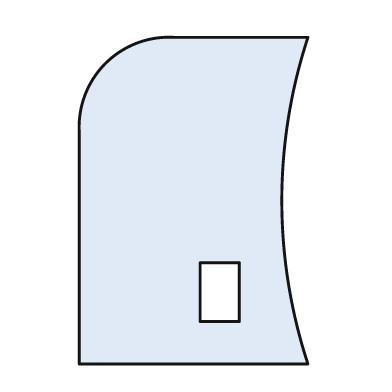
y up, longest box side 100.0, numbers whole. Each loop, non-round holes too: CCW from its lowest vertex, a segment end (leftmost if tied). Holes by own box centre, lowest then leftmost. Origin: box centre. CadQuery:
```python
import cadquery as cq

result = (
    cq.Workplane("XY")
    .moveTo(-35.0, -50.0)
    .lineTo(35.0, -50.0)
    .threePointArc((27.0, 0.0), (35.0, 50.0))
    .lineTo(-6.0, 50.0)
    .threePointArc((-27.0, 42.0), (-35.0, 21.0))
    .close()
    .moveTo(2.0, -37.0)
    .lineTo(14.0, -37.0)
    .lineTo(14.0, -19.0)
    .lineTo(2.0, -19.0)
    .close()
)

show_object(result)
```